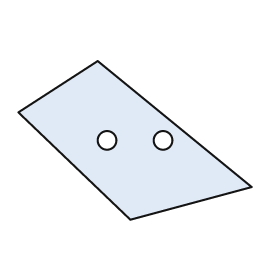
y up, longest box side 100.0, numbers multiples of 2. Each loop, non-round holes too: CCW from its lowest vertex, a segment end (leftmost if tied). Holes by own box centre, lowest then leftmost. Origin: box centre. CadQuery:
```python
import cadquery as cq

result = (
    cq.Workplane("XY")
    .moveTo(-2.0, -34.0)
    .lineTo(50.0, -20.0)
    .lineTo(-16.0, 34.0)
    .lineTo(-50.0, 12.0)
    .close()
    .moveTo(-12.0, 0.0)
    .circle(4.0)
    .moveTo(12.0, 0.0)
    .circle(4.0)
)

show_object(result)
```